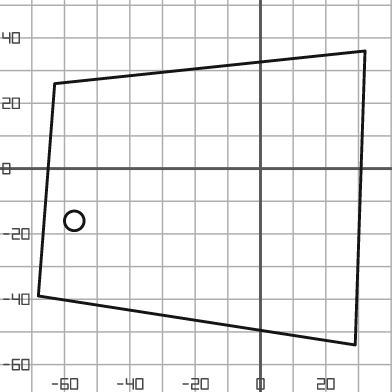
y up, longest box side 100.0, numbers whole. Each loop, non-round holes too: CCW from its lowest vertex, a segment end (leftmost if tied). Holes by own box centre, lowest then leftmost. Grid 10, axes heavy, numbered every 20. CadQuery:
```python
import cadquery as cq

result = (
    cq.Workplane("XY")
    .moveTo(29.0, -54.0)
    .lineTo(32.0, 36.0)
    .lineTo(-63.0, 26.0)
    .lineTo(-68.0, -39.0)
    .close()
    .moveTo(-57.0, -16.0)
    .circle(3.0)
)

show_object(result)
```